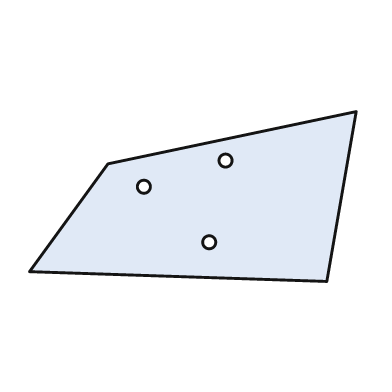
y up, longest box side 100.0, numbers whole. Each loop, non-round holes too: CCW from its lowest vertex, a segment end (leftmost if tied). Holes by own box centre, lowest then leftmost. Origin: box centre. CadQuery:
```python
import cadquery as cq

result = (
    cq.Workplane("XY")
    .moveTo(41.0, -26.0)
    .lineTo(50.0, 26.0)
    .lineTo(-26.0, 10.0)
    .lineTo(-50.0, -23.0)
    .close()
    .moveTo(5.0, -14.0)
    .circle(2.0)
    .moveTo(-15.0, 3.0)
    .circle(2.0)
    .moveTo(10.0, 11.0)
    .circle(2.0)
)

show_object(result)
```